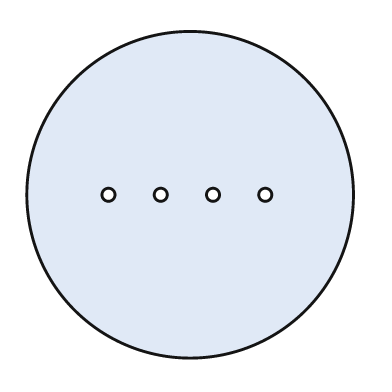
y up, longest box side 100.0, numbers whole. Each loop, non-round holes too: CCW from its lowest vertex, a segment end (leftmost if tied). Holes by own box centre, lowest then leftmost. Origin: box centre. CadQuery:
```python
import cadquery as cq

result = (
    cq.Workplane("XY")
    .moveTo(0.0, 0.0)
    .circle(50.0)
    .moveTo(-25.0, 0.0)
    .circle(2.0)
    .moveTo(-9.0, 0.0)
    .circle(2.0)
    .moveTo(7.0, 0.0)
    .circle(2.0)
    .moveTo(23.0, 0.0)
    .circle(2.0)
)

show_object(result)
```